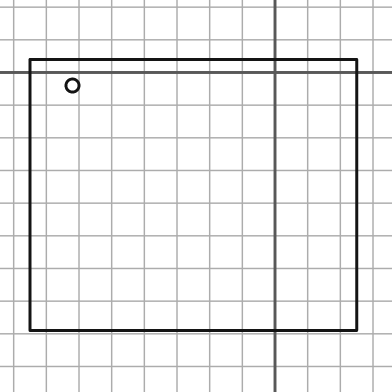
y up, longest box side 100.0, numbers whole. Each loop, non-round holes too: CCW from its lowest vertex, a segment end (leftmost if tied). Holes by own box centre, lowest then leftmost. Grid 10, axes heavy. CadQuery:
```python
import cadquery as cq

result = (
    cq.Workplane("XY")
    .moveTo(-75.0, -79.0)
    .lineTo(25.0, -79.0)
    .lineTo(25.0, 4.0)
    .lineTo(-75.0, 4.0)
    .close()
    .moveTo(-62.0, -4.0)
    .circle(2.0)
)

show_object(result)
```